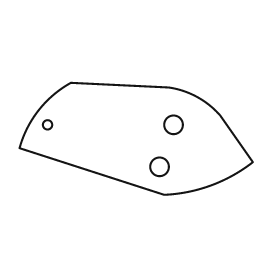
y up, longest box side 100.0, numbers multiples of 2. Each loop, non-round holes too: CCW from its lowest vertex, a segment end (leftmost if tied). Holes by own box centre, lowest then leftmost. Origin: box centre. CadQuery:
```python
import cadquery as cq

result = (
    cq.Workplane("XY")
    .moveTo(12.0, -24.0)
    .threePointArc((32.0, -20.0), (50.0, -10.0))
    .lineTo(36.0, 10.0)
    .threePointArc((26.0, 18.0), (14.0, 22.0))
    .lineTo(-28.0, 24.0)
    .threePointArc((-42.0, 12.0), (-50.0, -4.0))
    .close()
    .moveTo(10.0, -12.0)
    .circle(4.0)
    .moveTo(-38.0, 6.0)
    .circle(2.0)
    .moveTo(16.0, 6.0)
    .circle(4.0)
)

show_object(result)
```